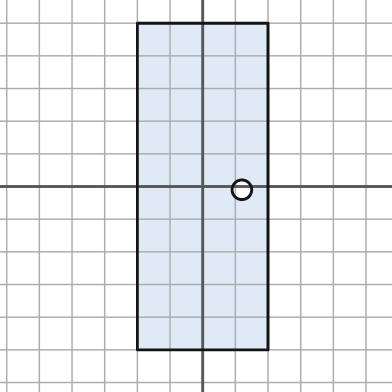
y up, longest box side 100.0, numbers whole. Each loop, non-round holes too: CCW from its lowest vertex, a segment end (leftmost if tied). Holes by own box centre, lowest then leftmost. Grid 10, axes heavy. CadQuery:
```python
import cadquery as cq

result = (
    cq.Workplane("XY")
    .moveTo(-20.0, -50.0)
    .lineTo(20.0, -50.0)
    .lineTo(20.0, 50.0)
    .lineTo(-20.0, 50.0)
    .close()
    .moveTo(12.0, -1.0)
    .circle(3.0)
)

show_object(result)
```